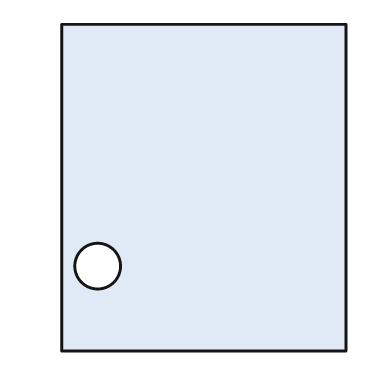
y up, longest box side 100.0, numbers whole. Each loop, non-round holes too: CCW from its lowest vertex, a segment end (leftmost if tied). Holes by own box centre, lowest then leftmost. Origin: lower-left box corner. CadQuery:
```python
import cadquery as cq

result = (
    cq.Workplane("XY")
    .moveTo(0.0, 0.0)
    .lineTo(87.0, 0.0)
    .lineTo(87.0, 100.0)
    .lineTo(0.0, 100.0)
    .close()
    .moveTo(11.0, 26.0)
    .circle(7.0)
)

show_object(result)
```